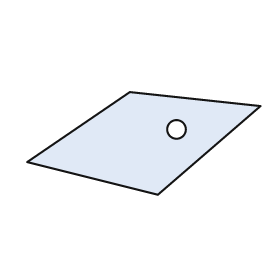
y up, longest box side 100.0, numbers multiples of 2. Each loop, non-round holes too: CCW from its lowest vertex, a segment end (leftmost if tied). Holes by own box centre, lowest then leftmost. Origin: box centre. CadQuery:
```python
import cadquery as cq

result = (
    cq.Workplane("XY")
    .moveTo(6.0, -22.0)
    .lineTo(50.0, 16.0)
    .lineTo(-6.0, 22.0)
    .lineTo(-50.0, -8.0)
    .close()
    .moveTo(14.0, 6.0)
    .circle(4.0)
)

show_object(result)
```